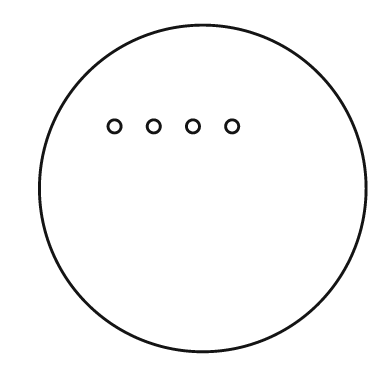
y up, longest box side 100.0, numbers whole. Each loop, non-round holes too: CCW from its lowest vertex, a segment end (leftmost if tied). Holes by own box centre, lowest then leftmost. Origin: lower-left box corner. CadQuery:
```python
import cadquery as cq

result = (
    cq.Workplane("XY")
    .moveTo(50.0, 50.0)
    .circle(50.0)
    .moveTo(23.0, 69.0)
    .circle(2.0)
    .moveTo(35.0, 69.0)
    .circle(2.0)
    .moveTo(47.0, 69.0)
    .circle(2.0)
    .moveTo(59.0, 69.0)
    .circle(2.0)
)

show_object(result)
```